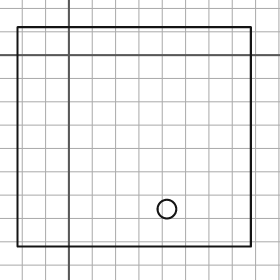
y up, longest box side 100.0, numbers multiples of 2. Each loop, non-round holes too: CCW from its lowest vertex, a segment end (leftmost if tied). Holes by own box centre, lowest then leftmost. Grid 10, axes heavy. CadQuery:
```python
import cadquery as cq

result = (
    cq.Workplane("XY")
    .moveTo(-22.0, -82.0)
    .lineTo(78.0, -82.0)
    .lineTo(78.0, 12.0)
    .lineTo(-22.0, 12.0)
    .close()
    .moveTo(42.0, -66.0)
    .circle(4.0)
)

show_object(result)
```